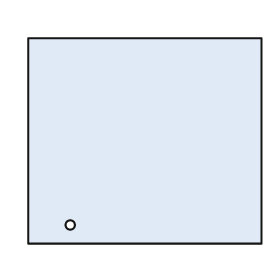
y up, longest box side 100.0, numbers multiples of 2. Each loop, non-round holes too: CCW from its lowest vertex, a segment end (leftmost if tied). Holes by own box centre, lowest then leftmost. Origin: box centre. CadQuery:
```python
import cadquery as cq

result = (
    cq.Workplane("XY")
    .moveTo(-50.0, -44.0)
    .lineTo(50.0, -44.0)
    .lineTo(50.0, 44.0)
    .lineTo(-50.0, 44.0)
    .close()
    .moveTo(-32.0, -36.0)
    .circle(2.0)
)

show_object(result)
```